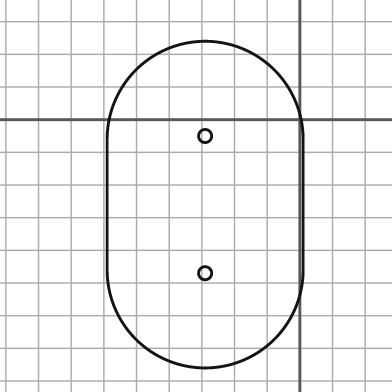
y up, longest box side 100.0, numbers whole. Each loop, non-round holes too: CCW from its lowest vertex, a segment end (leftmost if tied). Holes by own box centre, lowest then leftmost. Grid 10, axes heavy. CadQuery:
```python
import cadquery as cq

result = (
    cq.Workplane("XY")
    .moveTo(-59.0, -46.0)
    .threePointArc((-29.0, -76.0), (1.0, -46.0))
    .lineTo(1.0, -6.0)
    .threePointArc((-29.0, 24.0), (-59.0, -6.0))
    .close()
    .moveTo(-29.0, -47.0)
    .circle(2.0)
    .moveTo(-29.0, -5.0)
    .circle(2.0)
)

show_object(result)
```